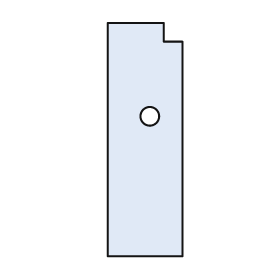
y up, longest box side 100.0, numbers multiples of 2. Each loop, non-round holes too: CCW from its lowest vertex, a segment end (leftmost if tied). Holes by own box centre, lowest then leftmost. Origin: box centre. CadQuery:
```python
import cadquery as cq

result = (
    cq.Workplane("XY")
    .moveTo(-16.0, -50.0)
    .lineTo(16.0, -50.0)
    .lineTo(16.0, 42.0)
    .lineTo(8.0, 42.0)
    .lineTo(8.0, 50.0)
    .lineTo(-16.0, 50.0)
    .close()
    .moveTo(2.0, 10.0)
    .circle(4.0)
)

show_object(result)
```